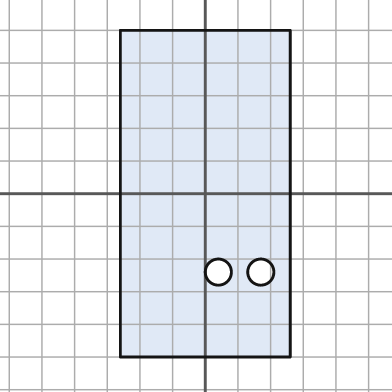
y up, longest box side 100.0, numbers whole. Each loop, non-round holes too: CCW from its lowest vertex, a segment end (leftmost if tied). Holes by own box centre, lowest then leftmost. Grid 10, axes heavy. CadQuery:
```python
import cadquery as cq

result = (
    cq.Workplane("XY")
    .moveTo(-26.0, -50.0)
    .lineTo(26.0, -50.0)
    .lineTo(26.0, 50.0)
    .lineTo(-26.0, 50.0)
    .close()
    .moveTo(4.0, -24.0)
    .circle(4.0)
    .moveTo(17.0, -24.0)
    .circle(4.0)
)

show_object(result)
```